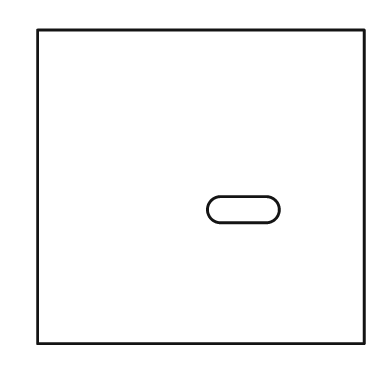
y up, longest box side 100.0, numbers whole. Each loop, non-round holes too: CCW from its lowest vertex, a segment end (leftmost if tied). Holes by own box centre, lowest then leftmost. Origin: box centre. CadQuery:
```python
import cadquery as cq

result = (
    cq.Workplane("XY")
    .moveTo(-50.0, -48.0)
    .lineTo(50.0, -48.0)
    .lineTo(50.0, 48.0)
    .lineTo(-50.0, 48.0)
    .close()
    .moveTo(6.0, -11.0)
    .lineTo(20.0, -11.0)
    .threePointArc((24.0, -7.0), (20.0, -3.0))
    .lineTo(6.0, -3.0)
    .threePointArc((2.0, -7.0), (6.0, -11.0))
    .close()
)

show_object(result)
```